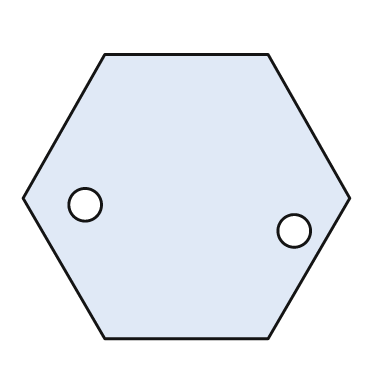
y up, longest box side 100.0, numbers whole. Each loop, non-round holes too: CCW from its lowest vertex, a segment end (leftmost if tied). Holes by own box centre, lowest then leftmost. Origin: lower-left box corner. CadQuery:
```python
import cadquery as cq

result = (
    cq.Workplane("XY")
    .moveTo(25.0, 0.0)
    .lineTo(75.0, 0.0)
    .lineTo(100.0, 43.0)
    .lineTo(75.0, 87.0)
    .lineTo(25.0, 87.0)
    .lineTo(0.0, 43.0)
    .close()
    .moveTo(83.0, 33.0)
    .circle(5.0)
    .moveTo(19.0, 41.0)
    .circle(5.0)
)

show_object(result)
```